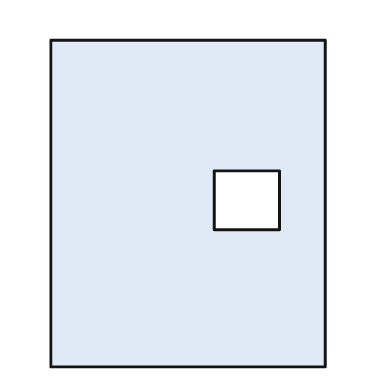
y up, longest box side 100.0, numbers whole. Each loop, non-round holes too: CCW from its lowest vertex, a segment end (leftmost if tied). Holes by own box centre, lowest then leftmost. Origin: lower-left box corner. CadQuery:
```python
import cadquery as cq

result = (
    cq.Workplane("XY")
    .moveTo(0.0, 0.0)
    .lineTo(84.0, 0.0)
    .lineTo(84.0, 100.0)
    .lineTo(0.0, 100.0)
    .close()
    .moveTo(50.0, 42.0)
    .lineTo(70.0, 42.0)
    .lineTo(70.0, 60.0)
    .lineTo(50.0, 60.0)
    .close()
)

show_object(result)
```